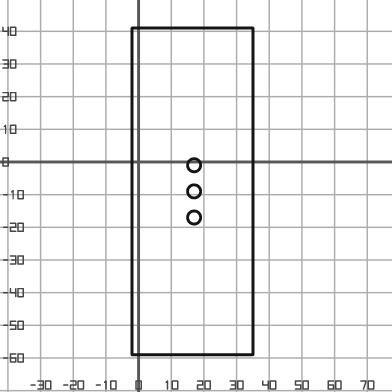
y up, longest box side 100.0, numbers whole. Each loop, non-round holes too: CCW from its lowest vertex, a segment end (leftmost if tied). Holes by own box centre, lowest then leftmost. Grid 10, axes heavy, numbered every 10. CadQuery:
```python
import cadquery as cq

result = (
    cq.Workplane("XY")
    .moveTo(-2.0, -59.0)
    .lineTo(35.0, -59.0)
    .lineTo(35.0, 41.0)
    .lineTo(-2.0, 41.0)
    .close()
    .moveTo(17.0, -17.0)
    .circle(2.0)
    .moveTo(17.0, -9.0)
    .circle(2.0)
    .moveTo(17.0, -1.0)
    .circle(2.0)
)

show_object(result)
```